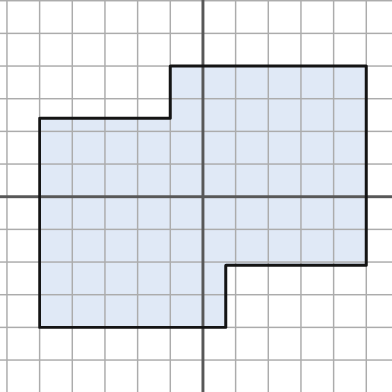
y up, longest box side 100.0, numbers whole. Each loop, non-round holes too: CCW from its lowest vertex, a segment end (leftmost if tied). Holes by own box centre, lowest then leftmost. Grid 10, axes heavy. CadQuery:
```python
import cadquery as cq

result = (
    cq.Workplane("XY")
    .moveTo(-50.0, -40.0)
    .lineTo(7.0, -40.0)
    .lineTo(7.0, -21.0)
    .lineTo(50.0, -21.0)
    .lineTo(50.0, 40.0)
    .lineTo(-10.0, 40.0)
    .lineTo(-10.0, 24.0)
    .lineTo(-50.0, 24.0)
    .close()
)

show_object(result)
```